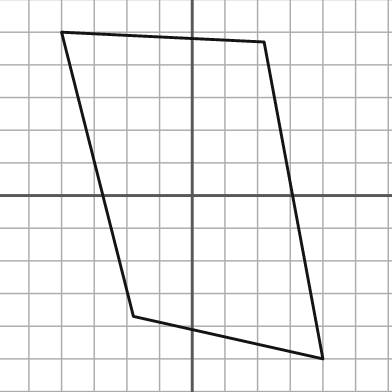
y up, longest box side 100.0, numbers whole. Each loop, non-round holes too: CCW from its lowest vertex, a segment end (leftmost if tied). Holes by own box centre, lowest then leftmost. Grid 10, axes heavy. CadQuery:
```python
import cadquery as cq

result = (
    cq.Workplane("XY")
    .moveTo(40.0, -50.0)
    .lineTo(22.0, 47.0)
    .lineTo(-40.0, 50.0)
    .lineTo(-18.0, -37.0)
    .close()
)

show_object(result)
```